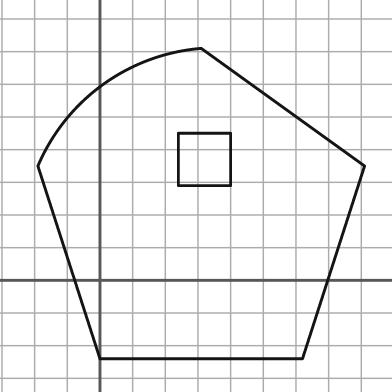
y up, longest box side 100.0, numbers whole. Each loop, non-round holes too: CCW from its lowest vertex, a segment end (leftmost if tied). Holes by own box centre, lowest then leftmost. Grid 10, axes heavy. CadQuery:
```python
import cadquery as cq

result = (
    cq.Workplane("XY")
    .moveTo(0.0, -24.0)
    .lineTo(62.0, -24.0)
    .lineTo(81.0, 35.0)
    .lineTo(31.0, 71.0)
    .threePointArc((1.0, 60.0), (-19.0, 35.0))
    .close()
    .moveTo(24.0, 29.0)
    .lineTo(40.0, 29.0)
    .lineTo(40.0, 45.0)
    .lineTo(24.0, 45.0)
    .close()
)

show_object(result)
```